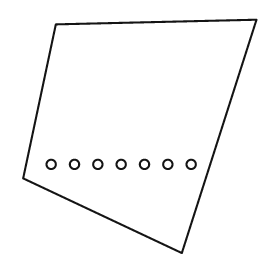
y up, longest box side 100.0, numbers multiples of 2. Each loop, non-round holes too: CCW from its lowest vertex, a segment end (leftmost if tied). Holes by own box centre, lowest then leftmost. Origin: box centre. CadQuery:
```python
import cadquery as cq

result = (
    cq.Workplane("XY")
    .moveTo(18.0, -50.0)
    .lineTo(50.0, 50.0)
    .lineTo(-36.0, 48.0)
    .lineTo(-50.0, -18.0)
    .close()
    .moveTo(-38.0, -12.0)
    .circle(2.0)
    .moveTo(-28.0, -12.0)
    .circle(2.0)
    .moveTo(-18.0, -12.0)
    .circle(2.0)
    .moveTo(-8.0, -12.0)
    .circle(2.0)
    .moveTo(2.0, -12.0)
    .circle(2.0)
    .moveTo(12.0, -12.0)
    .circle(2.0)
    .moveTo(22.0, -12.0)
    .circle(2.0)
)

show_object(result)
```